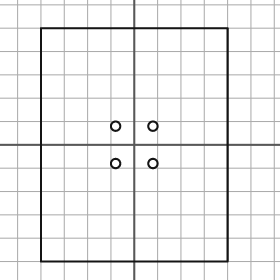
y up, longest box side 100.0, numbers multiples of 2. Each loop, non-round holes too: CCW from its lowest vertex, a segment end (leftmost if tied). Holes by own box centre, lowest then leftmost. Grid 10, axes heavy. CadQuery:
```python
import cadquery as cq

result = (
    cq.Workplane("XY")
    .moveTo(-40.0, -50.0)
    .lineTo(40.0, -50.0)
    .lineTo(40.0, 50.0)
    .lineTo(-40.0, 50.0)
    .close()
    .moveTo(-8.0, -8.0)
    .circle(2.0)
    .moveTo(8.0, -8.0)
    .circle(2.0)
    .moveTo(-8.0, 8.0)
    .circle(2.0)
    .moveTo(8.0, 8.0)
    .circle(2.0)
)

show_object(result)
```